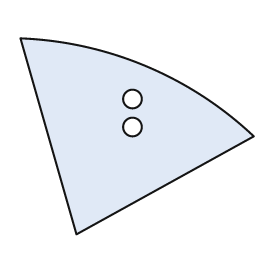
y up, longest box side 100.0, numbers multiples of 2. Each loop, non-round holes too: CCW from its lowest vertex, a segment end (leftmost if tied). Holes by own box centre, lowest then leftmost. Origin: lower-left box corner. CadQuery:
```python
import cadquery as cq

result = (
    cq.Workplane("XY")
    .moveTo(24.0, 0.0)
    .lineTo(100.0, 42.0)
    .threePointArc((54.0, 72.0), (0.0, 84.0))
    .close()
    .moveTo(48.0, 46.0)
    .circle(4.0)
    .moveTo(48.0, 58.0)
    .circle(4.0)
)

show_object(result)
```